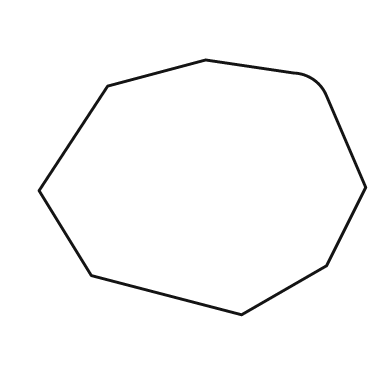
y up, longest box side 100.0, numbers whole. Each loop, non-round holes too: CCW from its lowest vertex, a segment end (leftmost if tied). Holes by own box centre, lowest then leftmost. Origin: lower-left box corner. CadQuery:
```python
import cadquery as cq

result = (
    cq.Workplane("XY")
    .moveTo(62.0, 0.0)
    .lineTo(88.0, 15.0)
    .lineTo(100.0, 39.0)
    .lineTo(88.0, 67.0)
    .threePointArc((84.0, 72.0), (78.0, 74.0))
    .lineTo(51.0, 78.0)
    .lineTo(21.0, 70.0)
    .lineTo(0.0, 38.0)
    .lineTo(16.0, 12.0)
    .close()
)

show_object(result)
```